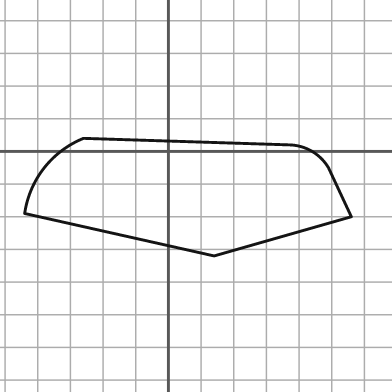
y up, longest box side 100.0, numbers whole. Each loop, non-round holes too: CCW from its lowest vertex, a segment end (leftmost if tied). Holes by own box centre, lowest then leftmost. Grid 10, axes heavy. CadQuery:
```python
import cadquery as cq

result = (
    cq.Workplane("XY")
    .moveTo(14.0, -32.0)
    .lineTo(56.0, -20.0)
    .lineTo(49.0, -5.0)
    .threePointArc((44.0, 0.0), (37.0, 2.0))
    .lineTo(-26.0, 4.0)
    .threePointArc((-38.0, -5.0), (-44.0, -19.0))
    .close()
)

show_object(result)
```